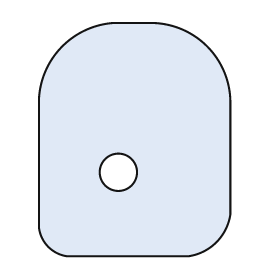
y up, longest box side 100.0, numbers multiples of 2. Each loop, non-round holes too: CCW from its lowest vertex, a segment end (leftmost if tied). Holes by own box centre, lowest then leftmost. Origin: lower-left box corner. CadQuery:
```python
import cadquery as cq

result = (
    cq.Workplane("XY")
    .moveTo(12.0, 0.0)
    .lineTo(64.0, 0.0)
    .threePointArc((76.0, 6.0), (82.0, 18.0))
    .lineTo(82.0, 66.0)
    .threePointArc((72.0, 90.0), (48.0, 100.0))
    .lineTo(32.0, 100.0)
    .threePointArc((10.0, 90.0), (0.0, 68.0))
    .lineTo(0.0, 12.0)
    .threePointArc((4.0, 4.0), (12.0, 0.0))
    .close()
    .moveTo(34.0, 36.0)
    .circle(8.0)
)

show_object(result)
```